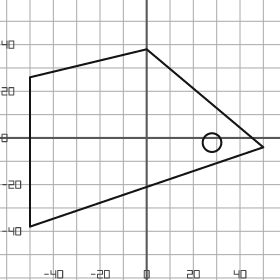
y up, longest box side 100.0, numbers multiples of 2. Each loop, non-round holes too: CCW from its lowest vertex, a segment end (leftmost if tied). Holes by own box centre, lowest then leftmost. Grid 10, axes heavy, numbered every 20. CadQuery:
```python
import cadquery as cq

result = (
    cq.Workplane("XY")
    .moveTo(-50.0, -38.0)
    .lineTo(50.0, -4.0)
    .lineTo(0.0, 38.0)
    .lineTo(-50.0, 26.0)
    .close()
    .moveTo(28.0, -2.0)
    .circle(4.0)
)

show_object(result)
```